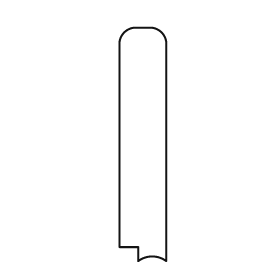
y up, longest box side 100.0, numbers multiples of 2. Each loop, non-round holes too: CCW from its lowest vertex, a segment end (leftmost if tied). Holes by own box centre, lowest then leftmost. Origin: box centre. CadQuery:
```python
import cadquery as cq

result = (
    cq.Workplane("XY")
    .moveTo(-2.0, -50.0)
    .threePointArc((4.0, -48.0), (10.0, -50.0))
    .lineTo(10.0, 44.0)
    .threePointArc((8.0, 48.0), (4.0, 50.0))
    .lineTo(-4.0, 50.0)
    .threePointArc((-8.0, 48.0), (-10.0, 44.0))
    .lineTo(-10.0, -44.0)
    .lineTo(-2.0, -44.0)
    .close()
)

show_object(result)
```